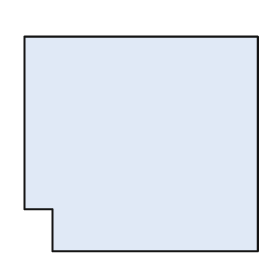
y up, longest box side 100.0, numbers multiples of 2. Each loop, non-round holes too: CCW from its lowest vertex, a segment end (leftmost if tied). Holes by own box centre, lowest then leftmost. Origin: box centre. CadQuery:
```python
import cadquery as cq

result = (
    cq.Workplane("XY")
    .moveTo(-38.0, -46.0)
    .lineTo(50.0, -46.0)
    .lineTo(50.0, 46.0)
    .lineTo(-50.0, 46.0)
    .lineTo(-50.0, -28.0)
    .lineTo(-38.0, -28.0)
    .close()
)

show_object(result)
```